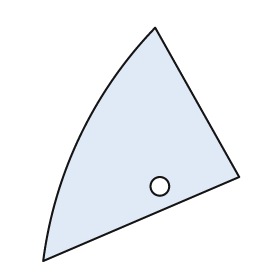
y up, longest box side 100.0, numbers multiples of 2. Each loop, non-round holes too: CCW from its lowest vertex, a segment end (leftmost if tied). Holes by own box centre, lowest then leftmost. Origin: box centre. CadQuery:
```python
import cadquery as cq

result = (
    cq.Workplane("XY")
    .moveTo(-42.0, -50.0)
    .lineTo(42.0, -14.0)
    .lineTo(6.0, 50.0)
    .threePointArc((-26.0, 4.0), (-42.0, -50.0))
    .close()
    .moveTo(8.0, -18.0)
    .circle(4.0)
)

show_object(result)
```